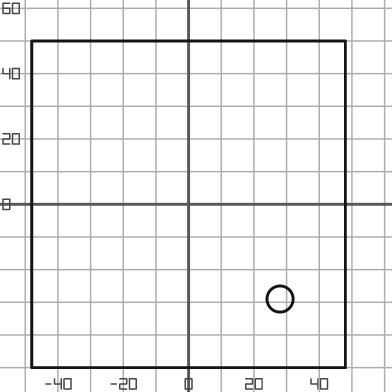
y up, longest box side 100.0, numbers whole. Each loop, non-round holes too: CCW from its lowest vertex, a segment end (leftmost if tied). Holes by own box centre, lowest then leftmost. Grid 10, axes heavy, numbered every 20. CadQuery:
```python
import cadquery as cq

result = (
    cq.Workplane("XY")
    .moveTo(-48.0, -50.0)
    .lineTo(48.0, -50.0)
    .lineTo(48.0, 50.0)
    .lineTo(-48.0, 50.0)
    .close()
    .moveTo(28.0, -29.0)
    .circle(4.0)
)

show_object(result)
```